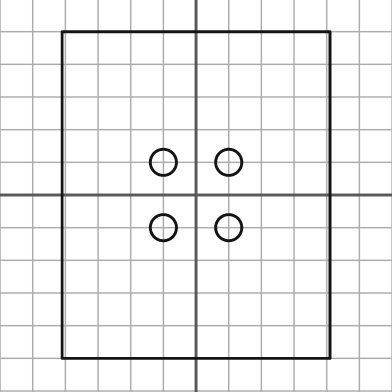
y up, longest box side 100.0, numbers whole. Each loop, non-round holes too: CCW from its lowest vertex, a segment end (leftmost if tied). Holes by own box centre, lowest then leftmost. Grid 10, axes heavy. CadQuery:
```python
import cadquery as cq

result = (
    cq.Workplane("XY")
    .moveTo(-41.0, -50.0)
    .lineTo(41.0, -50.0)
    .lineTo(41.0, 50.0)
    .lineTo(-41.0, 50.0)
    .close()
    .moveTo(-10.0, -10.0)
    .circle(4.0)
    .moveTo(10.0, -10.0)
    .circle(4.0)
    .moveTo(-10.0, 10.0)
    .circle(4.0)
    .moveTo(10.0, 10.0)
    .circle(4.0)
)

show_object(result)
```